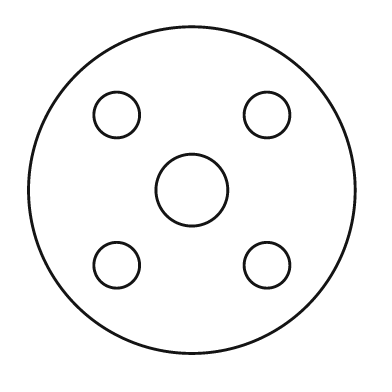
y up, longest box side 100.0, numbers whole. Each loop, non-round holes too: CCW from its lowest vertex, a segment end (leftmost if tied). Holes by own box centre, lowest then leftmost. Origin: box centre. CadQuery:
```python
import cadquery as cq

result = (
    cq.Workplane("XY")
    .moveTo(0.0, 0.0)
    .circle(50.0)
    .moveTo(-23.0, -23.0)
    .circle(7.0)
    .moveTo(23.0, -23.0)
    .circle(7.0)
    .moveTo(0.0, 0.0)
    .circle(11.0)
    .moveTo(-23.0, 23.0)
    .circle(7.0)
    .moveTo(23.0, 23.0)
    .circle(7.0)
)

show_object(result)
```